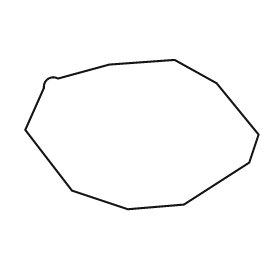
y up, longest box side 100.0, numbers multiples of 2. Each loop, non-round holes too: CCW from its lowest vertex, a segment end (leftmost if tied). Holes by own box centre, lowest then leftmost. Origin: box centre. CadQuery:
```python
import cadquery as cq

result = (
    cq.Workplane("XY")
    .moveTo(-6.0, -32.0)
    .lineTo(18.0, -30.0)
    .lineTo(46.0, -12.0)
    .lineTo(50.0, 0.0)
    .lineTo(32.0, 22.0)
    .lineTo(14.0, 32.0)
    .lineTo(-14.0, 30.0)
    .lineTo(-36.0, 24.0)
    .threePointArc((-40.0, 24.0), (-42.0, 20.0))
    .lineTo(-50.0, 2.0)
    .lineTo(-30.0, -24.0)
    .close()
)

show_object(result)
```